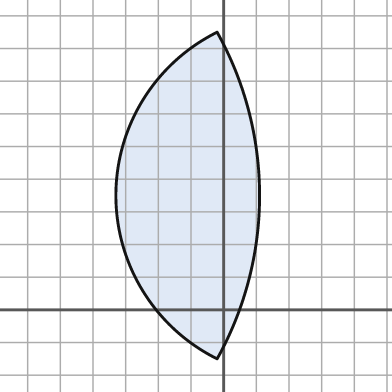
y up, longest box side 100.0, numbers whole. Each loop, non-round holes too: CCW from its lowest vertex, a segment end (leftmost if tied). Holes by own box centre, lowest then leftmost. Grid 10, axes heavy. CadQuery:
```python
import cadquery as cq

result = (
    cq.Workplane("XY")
    .moveTo(-2.0, -15.0)
    .threePointArc((11.0, 35.0), (-2.0, 85.0))
    .threePointArc((-33.0, 35.0), (-2.0, -15.0))
    .close()
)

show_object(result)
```